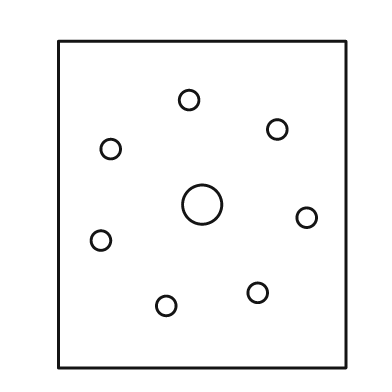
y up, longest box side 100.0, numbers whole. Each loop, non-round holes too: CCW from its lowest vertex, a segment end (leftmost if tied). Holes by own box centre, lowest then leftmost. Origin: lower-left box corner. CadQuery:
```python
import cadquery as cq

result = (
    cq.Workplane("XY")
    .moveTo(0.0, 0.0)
    .lineTo(88.0, 0.0)
    .lineTo(88.0, 100.0)
    .lineTo(0.0, 100.0)
    .close()
    .moveTo(33.0, 19.0)
    .circle(3.0)
    .moveTo(61.0, 23.0)
    .circle(3.0)
    .moveTo(13.0, 39.0)
    .circle(3.0)
    .moveTo(76.0, 46.0)
    .circle(3.0)
    .moveTo(44.0, 50.0)
    .circle(6.0)
    .moveTo(16.0, 67.0)
    .circle(3.0)
    .moveTo(67.0, 73.0)
    .circle(3.0)
    .moveTo(40.0, 82.0)
    .circle(3.0)
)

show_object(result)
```